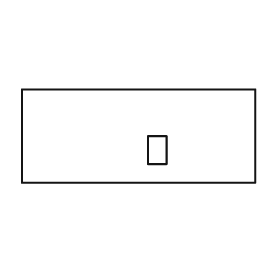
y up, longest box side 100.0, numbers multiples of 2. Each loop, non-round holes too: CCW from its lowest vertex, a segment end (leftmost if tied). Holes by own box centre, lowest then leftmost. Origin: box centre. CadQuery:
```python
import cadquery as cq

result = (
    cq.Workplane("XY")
    .moveTo(-50.0, -20.0)
    .lineTo(50.0, -20.0)
    .lineTo(50.0, 20.0)
    .lineTo(-50.0, 20.0)
    .close()
    .moveTo(4.0, -12.0)
    .lineTo(12.0, -12.0)
    .lineTo(12.0, 0.0)
    .lineTo(4.0, 0.0)
    .close()
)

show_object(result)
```